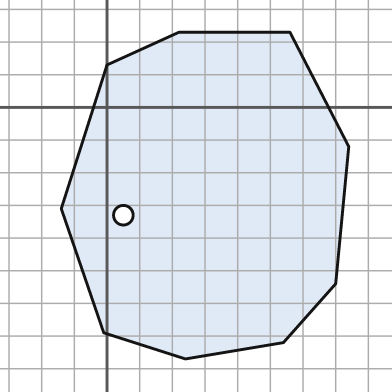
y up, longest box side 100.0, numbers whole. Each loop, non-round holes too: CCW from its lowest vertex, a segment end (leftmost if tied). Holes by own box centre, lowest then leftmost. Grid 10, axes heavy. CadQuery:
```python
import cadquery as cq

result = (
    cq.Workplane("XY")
    .moveTo(24.0, -77.0)
    .lineTo(54.0, -72.0)
    .lineTo(70.0, -54.0)
    .lineTo(74.0, -12.0)
    .lineTo(56.0, 23.0)
    .lineTo(22.0, 23.0)
    .lineTo(0.0, 13.0)
    .lineTo(-14.0, -31.0)
    .lineTo(-1.0, -69.0)
    .close()
    .moveTo(5.0, -33.0)
    .circle(3.0)
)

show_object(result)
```